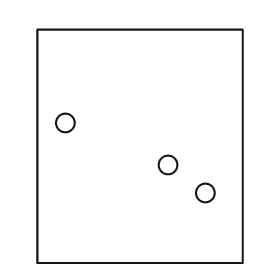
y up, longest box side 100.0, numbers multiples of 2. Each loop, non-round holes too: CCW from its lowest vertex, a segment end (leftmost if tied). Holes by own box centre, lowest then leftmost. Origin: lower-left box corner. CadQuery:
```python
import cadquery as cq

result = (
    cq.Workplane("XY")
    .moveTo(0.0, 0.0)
    .lineTo(88.0, 0.0)
    .lineTo(88.0, 100.0)
    .lineTo(0.0, 100.0)
    .close()
    .moveTo(72.0, 30.0)
    .circle(4.0)
    .moveTo(56.0, 42.0)
    .circle(4.0)
    .moveTo(12.0, 60.0)
    .circle(4.0)
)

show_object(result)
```